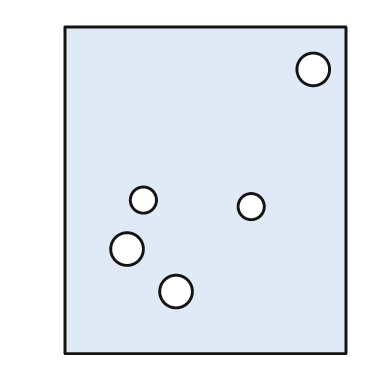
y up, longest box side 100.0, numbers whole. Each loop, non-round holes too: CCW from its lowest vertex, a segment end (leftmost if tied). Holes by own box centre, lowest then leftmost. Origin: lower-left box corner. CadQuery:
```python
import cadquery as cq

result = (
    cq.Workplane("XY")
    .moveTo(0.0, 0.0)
    .lineTo(86.0, 0.0)
    .lineTo(86.0, 100.0)
    .lineTo(0.0, 100.0)
    .close()
    .moveTo(34.0, 19.0)
    .circle(5.0)
    .moveTo(19.0, 32.0)
    .circle(5.0)
    .moveTo(57.0, 45.0)
    .circle(4.0)
    .moveTo(24.0, 47.0)
    .circle(4.0)
    .moveTo(76.0, 87.0)
    .circle(5.0)
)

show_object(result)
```